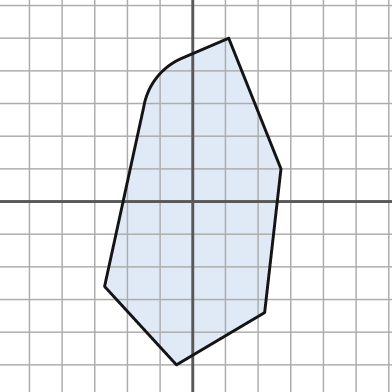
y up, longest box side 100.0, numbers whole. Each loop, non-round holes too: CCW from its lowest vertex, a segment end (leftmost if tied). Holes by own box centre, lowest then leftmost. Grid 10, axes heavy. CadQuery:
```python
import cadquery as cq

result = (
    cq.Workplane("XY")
    .moveTo(-5.0, -50.0)
    .lineTo(22.0, -34.0)
    .lineTo(27.0, 10.0)
    .lineTo(11.0, 50.0)
    .lineTo(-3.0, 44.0)
    .threePointArc((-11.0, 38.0), (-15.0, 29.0))
    .lineTo(-27.0, -26.0)
    .close()
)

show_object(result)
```